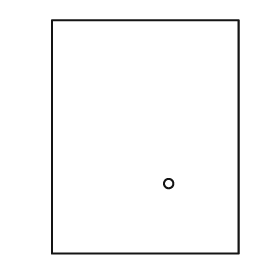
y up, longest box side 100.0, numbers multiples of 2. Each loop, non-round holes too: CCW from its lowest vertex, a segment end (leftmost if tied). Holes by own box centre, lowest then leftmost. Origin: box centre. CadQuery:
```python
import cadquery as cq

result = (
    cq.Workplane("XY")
    .moveTo(-40.0, -50.0)
    .lineTo(40.0, -50.0)
    .lineTo(40.0, 50.0)
    .lineTo(-40.0, 50.0)
    .close()
    .moveTo(10.0, -20.0)
    .circle(2.0)
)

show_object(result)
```